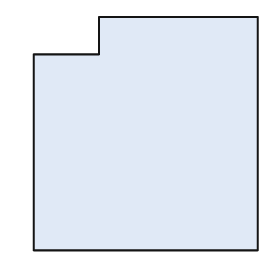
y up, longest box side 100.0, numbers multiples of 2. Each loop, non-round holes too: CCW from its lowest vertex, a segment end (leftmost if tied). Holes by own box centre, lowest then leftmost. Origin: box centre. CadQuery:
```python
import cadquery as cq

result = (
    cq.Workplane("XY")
    .moveTo(-48.0, -50.0)
    .lineTo(48.0, -50.0)
    .lineTo(48.0, 50.0)
    .lineTo(-20.0, 50.0)
    .lineTo(-20.0, 34.0)
    .lineTo(-48.0, 34.0)
    .close()
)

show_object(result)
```